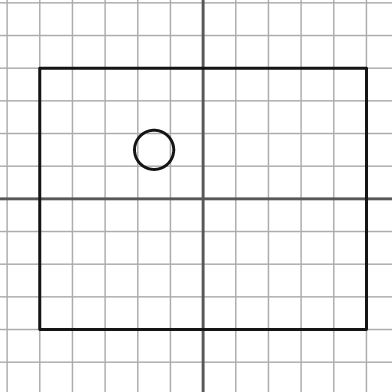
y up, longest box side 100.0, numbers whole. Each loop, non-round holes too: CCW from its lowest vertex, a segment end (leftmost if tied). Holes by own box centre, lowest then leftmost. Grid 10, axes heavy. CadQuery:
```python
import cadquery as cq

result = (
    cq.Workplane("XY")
    .moveTo(-50.0, -40.0)
    .lineTo(50.0, -40.0)
    .lineTo(50.0, 40.0)
    .lineTo(-50.0, 40.0)
    .close()
    .moveTo(-15.0, 15.0)
    .circle(6.0)
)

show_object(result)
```